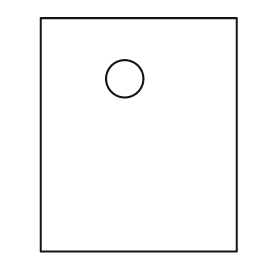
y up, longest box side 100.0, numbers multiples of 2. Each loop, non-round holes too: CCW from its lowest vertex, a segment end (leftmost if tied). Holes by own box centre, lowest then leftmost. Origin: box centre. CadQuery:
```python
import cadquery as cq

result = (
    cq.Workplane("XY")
    .moveTo(-42.0, -50.0)
    .lineTo(42.0, -50.0)
    .lineTo(42.0, 50.0)
    .lineTo(-42.0, 50.0)
    .close()
    .moveTo(-6.0, 24.0)
    .circle(8.0)
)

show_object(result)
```